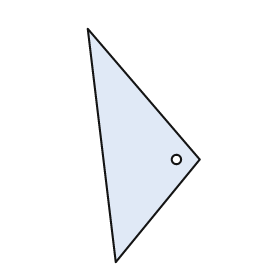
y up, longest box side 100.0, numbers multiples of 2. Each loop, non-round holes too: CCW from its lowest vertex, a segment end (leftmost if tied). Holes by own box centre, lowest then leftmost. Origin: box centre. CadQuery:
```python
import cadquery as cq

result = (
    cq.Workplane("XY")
    .moveTo(-12.0, -50.0)
    .lineTo(24.0, -6.0)
    .lineTo(-24.0, 50.0)
    .close()
    .moveTo(14.0, -6.0)
    .circle(2.0)
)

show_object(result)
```